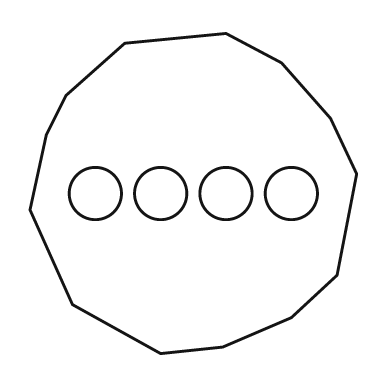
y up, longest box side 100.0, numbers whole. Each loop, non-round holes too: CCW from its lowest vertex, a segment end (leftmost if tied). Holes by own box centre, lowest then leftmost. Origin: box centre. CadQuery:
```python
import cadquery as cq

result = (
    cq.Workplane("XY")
    .moveTo(-10.0, -49.0)
    .lineTo(9.0, -47.0)
    .lineTo(30.0, -38.0)
    .lineTo(44.0, -25.0)
    .lineTo(50.0, 6.0)
    .lineTo(42.0, 23.0)
    .lineTo(27.0, 40.0)
    .lineTo(10.0, 49.0)
    .lineTo(-21.0, 46.0)
    .lineTo(-39.0, 30.0)
    .lineTo(-45.0, 18.0)
    .lineTo(-50.0, -5.0)
    .lineTo(-37.0, -34.0)
    .close()
    .moveTo(-30.0, 0.0)
    .circle(8.0)
    .moveTo(-10.0, 0.0)
    .circle(8.0)
    .moveTo(10.0, 0.0)
    .circle(8.0)
    .moveTo(30.0, 0.0)
    .circle(8.0)
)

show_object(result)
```